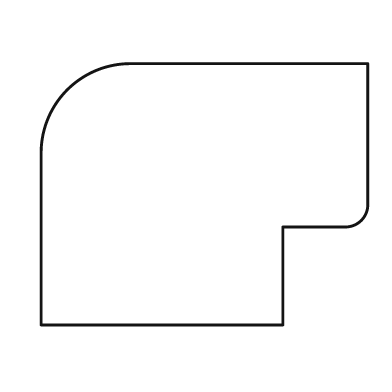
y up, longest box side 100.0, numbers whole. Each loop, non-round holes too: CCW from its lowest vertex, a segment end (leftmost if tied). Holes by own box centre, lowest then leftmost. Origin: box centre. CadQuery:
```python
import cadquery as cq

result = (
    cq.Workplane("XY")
    .moveTo(-50.0, -40.0)
    .lineTo(24.0, -40.0)
    .lineTo(24.0, -10.0)
    .lineTo(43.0, -10.0)
    .threePointArc((48.0, -8.0), (50.0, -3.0))
    .lineTo(50.0, 40.0)
    .lineTo(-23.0, 40.0)
    .threePointArc((-42.0, 32.0), (-50.0, 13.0))
    .close()
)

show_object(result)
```